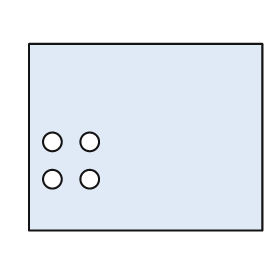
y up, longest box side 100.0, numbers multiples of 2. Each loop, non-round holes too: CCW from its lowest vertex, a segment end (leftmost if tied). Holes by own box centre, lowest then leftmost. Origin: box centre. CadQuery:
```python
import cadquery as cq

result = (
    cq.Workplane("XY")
    .moveTo(-50.0, -40.0)
    .lineTo(50.0, -40.0)
    .lineTo(50.0, 40.0)
    .lineTo(-50.0, 40.0)
    .close()
    .moveTo(-40.0, -18.0)
    .circle(4.0)
    .moveTo(-24.0, -18.0)
    .circle(4.0)
    .moveTo(-40.0, -2.0)
    .circle(4.0)
    .moveTo(-24.0, -2.0)
    .circle(4.0)
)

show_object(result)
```